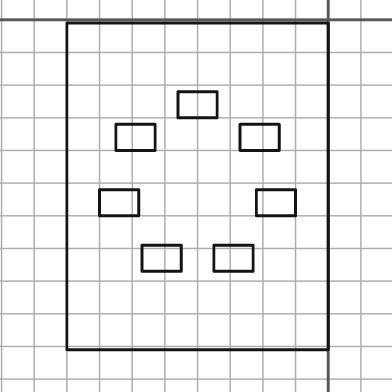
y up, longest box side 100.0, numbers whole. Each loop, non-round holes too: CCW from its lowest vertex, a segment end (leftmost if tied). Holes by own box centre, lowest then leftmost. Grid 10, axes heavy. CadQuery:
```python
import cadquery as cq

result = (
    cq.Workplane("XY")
    .moveTo(-80.0, -101.0)
    .lineTo(0.0, -101.0)
    .lineTo(0.0, -1.0)
    .lineTo(-80.0, -1.0)
    .close()
    .moveTo(-57.0, -77.0)
    .lineTo(-45.0, -77.0)
    .lineTo(-45.0, -69.0)
    .lineTo(-57.0, -69.0)
    .close()
    .moveTo(-35.0, -77.0)
    .lineTo(-23.0, -77.0)
    .lineTo(-23.0, -69.0)
    .lineTo(-35.0, -69.0)
    .close()
    .moveTo(-70.0, -60.0)
    .lineTo(-58.0, -60.0)
    .lineTo(-58.0, -52.0)
    .lineTo(-70.0, -52.0)
    .close()
    .moveTo(-22.0, -60.0)
    .lineTo(-10.0, -60.0)
    .lineTo(-10.0, -52.0)
    .lineTo(-22.0, -52.0)
    .close()
    .moveTo(-65.0, -40.0)
    .lineTo(-53.0, -40.0)
    .lineTo(-53.0, -32.0)
    .lineTo(-65.0, -32.0)
    .close()
    .moveTo(-27.0, -40.0)
    .lineTo(-15.0, -40.0)
    .lineTo(-15.0, -32.0)
    .lineTo(-27.0, -32.0)
    .close()
    .moveTo(-46.0, -30.0)
    .lineTo(-34.0, -30.0)
    .lineTo(-34.0, -22.0)
    .lineTo(-46.0, -22.0)
    .close()
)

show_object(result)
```